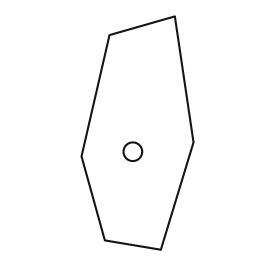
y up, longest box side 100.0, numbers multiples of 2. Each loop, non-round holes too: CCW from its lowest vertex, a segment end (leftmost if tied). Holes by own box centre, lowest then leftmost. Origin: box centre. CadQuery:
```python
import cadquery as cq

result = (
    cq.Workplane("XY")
    .moveTo(10.0, -50.0)
    .lineTo(24.0, -4.0)
    .lineTo(16.0, 50.0)
    .lineTo(-12.0, 42.0)
    .lineTo(-24.0, -10.0)
    .lineTo(-14.0, -46.0)
    .close()
    .moveTo(-2.0, -8.0)
    .circle(4.0)
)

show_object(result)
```